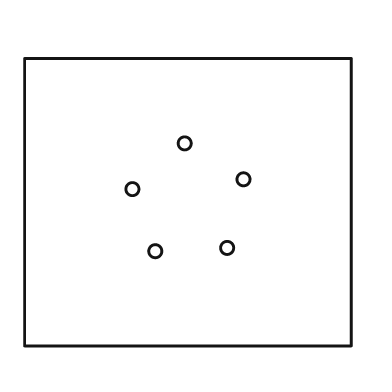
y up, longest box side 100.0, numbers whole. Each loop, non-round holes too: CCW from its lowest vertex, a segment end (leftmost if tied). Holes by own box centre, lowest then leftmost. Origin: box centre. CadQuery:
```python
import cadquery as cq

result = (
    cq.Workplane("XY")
    .moveTo(-50.0, -44.0)
    .lineTo(50.0, -44.0)
    .lineTo(50.0, 44.0)
    .lineTo(-50.0, 44.0)
    .close()
    .moveTo(-10.0, -15.0)
    .circle(2.0)
    .moveTo(12.0, -14.0)
    .circle(2.0)
    .moveTo(-17.0, 4.0)
    .circle(2.0)
    .moveTo(17.0, 7.0)
    .circle(2.0)
    .moveTo(-1.0, 18.0)
    .circle(2.0)
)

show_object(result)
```